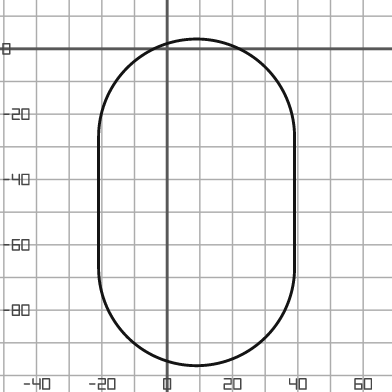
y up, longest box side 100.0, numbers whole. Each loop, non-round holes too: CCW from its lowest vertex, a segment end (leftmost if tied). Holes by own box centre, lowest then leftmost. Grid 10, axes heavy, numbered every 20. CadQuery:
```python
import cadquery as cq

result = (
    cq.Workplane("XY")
    .moveTo(-21.0, -67.0)
    .threePointArc((9.0, -97.0), (39.0, -67.0))
    .lineTo(39.0, -27.0)
    .threePointArc((9.0, 3.0), (-21.0, -27.0))
    .close()
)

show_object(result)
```